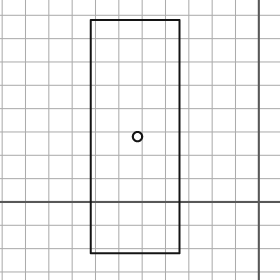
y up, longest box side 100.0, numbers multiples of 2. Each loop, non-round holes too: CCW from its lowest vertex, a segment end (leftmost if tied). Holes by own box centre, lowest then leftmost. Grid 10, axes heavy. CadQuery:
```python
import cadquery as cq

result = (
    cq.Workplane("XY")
    .moveTo(-72.0, -22.0)
    .lineTo(-34.0, -22.0)
    .lineTo(-34.0, 78.0)
    .lineTo(-72.0, 78.0)
    .close()
    .moveTo(-52.0, 28.0)
    .circle(2.0)
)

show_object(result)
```